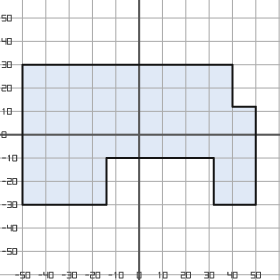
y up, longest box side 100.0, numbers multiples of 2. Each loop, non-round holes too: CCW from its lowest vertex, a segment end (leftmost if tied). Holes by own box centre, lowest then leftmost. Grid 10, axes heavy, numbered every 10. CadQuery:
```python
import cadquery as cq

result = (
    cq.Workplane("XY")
    .moveTo(-50.0, -30.0)
    .lineTo(-14.0, -30.0)
    .lineTo(-14.0, -10.0)
    .lineTo(32.0, -10.0)
    .lineTo(32.0, -30.0)
    .lineTo(50.0, -30.0)
    .lineTo(50.0, 12.0)
    .lineTo(40.0, 12.0)
    .lineTo(40.0, 30.0)
    .lineTo(-50.0, 30.0)
    .close()
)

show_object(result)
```